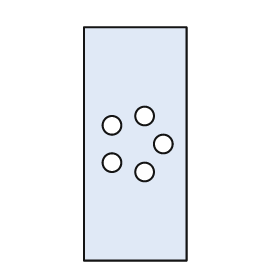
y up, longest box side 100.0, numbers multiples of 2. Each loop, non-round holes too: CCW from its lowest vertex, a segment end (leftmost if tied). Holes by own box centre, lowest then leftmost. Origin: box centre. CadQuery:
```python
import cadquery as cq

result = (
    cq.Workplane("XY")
    .moveTo(-22.0, -50.0)
    .lineTo(22.0, -50.0)
    .lineTo(22.0, 50.0)
    .lineTo(-22.0, 50.0)
    .close()
    .moveTo(4.0, -12.0)
    .circle(4.0)
    .moveTo(-10.0, -8.0)
    .circle(4.0)
    .moveTo(12.0, 0.0)
    .circle(4.0)
    .moveTo(-10.0, 8.0)
    .circle(4.0)
    .moveTo(4.0, 12.0)
    .circle(4.0)
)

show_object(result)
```